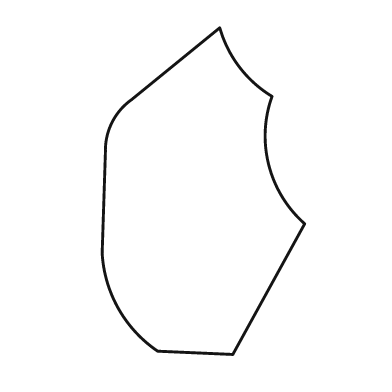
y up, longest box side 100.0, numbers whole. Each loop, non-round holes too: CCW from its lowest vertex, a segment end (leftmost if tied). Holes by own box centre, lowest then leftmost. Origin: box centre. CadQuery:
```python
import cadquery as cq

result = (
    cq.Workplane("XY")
    .moveTo(9.0, -50.0)
    .lineTo(31.0, -10.0)
    .threePointArc((20.0, 8.0), (21.0, 29.0))
    .threePointArc((11.0, 38.0), (5.0, 50.0))
    .lineTo(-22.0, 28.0)
    .threePointArc((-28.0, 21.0), (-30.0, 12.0))
    .lineTo(-31.0, -19.0)
    .threePointArc((-26.0, -36.0), (-14.0, -49.0))
    .close()
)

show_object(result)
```